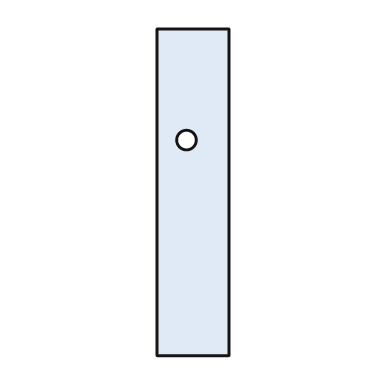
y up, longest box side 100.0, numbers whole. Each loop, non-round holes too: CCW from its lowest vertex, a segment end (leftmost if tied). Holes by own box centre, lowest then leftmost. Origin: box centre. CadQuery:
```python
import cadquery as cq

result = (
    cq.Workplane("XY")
    .moveTo(-11.0, -50.0)
    .lineTo(11.0, -50.0)
    .lineTo(11.0, 50.0)
    .lineTo(-11.0, 50.0)
    .close()
    .moveTo(-2.0, 16.0)
    .circle(3.0)
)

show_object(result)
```